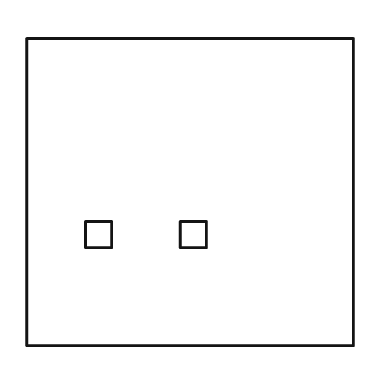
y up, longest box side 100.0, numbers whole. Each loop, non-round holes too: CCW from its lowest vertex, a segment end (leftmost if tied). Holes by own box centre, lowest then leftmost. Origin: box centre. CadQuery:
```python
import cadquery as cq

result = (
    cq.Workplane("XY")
    .moveTo(-50.0, -47.0)
    .lineTo(50.0, -47.0)
    .lineTo(50.0, 47.0)
    .lineTo(-50.0, 47.0)
    .close()
    .moveTo(-32.0, -17.0)
    .lineTo(-24.0, -17.0)
    .lineTo(-24.0, -9.0)
    .lineTo(-32.0, -9.0)
    .close()
    .moveTo(-3.0, -17.0)
    .lineTo(5.0, -17.0)
    .lineTo(5.0, -9.0)
    .lineTo(-3.0, -9.0)
    .close()
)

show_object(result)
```